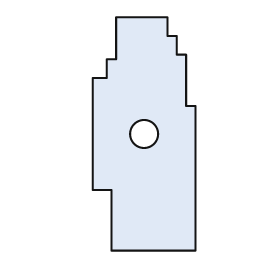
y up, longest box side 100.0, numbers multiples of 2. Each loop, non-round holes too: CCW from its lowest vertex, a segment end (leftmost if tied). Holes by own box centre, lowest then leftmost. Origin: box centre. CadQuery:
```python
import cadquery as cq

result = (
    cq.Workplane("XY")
    .moveTo(-14.0, -50.0)
    .lineTo(22.0, -50.0)
    .lineTo(22.0, 12.0)
    .lineTo(18.0, 12.0)
    .lineTo(18.0, 34.0)
    .lineTo(14.0, 34.0)
    .lineTo(14.0, 42.0)
    .lineTo(10.0, 42.0)
    .lineTo(10.0, 50.0)
    .lineTo(-12.0, 50.0)
    .lineTo(-12.0, 32.0)
    .lineTo(-16.0, 32.0)
    .lineTo(-16.0, 24.0)
    .lineTo(-22.0, 24.0)
    .lineTo(-22.0, -24.0)
    .lineTo(-14.0, -24.0)
    .close()
    .moveTo(0.0, 0.0)
    .circle(6.0)
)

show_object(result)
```